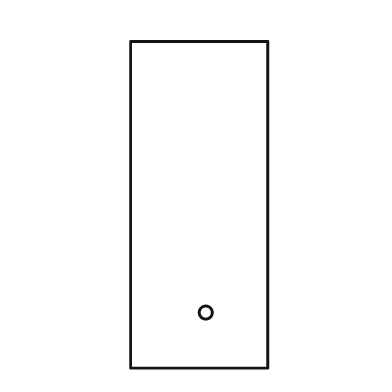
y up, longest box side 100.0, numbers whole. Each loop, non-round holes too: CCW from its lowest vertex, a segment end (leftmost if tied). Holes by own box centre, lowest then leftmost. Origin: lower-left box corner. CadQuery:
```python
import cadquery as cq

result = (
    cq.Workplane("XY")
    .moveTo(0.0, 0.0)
    .lineTo(42.0, 0.0)
    .lineTo(42.0, 100.0)
    .lineTo(0.0, 100.0)
    .close()
    .moveTo(23.0, 17.0)
    .circle(2.0)
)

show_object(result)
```